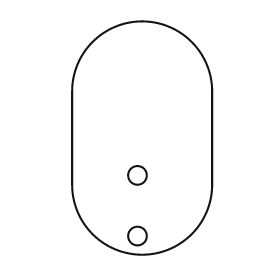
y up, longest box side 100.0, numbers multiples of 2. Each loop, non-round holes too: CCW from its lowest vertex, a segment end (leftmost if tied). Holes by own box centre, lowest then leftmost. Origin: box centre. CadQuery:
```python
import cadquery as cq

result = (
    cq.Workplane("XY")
    .moveTo(-30.0, -20.0)
    .threePointArc((0.0, -50.0), (30.0, -20.0))
    .lineTo(30.0, 20.0)
    .threePointArc((0.0, 50.0), (-30.0, 20.0))
    .close()
    .moveTo(-2.0, -42.0)
    .circle(4.0)
    .moveTo(-2.0, -16.0)
    .circle(4.0)
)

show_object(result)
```